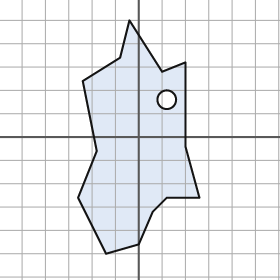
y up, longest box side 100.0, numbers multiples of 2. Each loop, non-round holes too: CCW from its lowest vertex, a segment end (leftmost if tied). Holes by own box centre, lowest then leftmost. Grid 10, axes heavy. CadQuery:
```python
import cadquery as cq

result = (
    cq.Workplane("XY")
    .moveTo(-14.0, -50.0)
    .lineTo(0.0, -46.0)
    .lineTo(6.0, -32.0)
    .lineTo(12.0, -26.0)
    .lineTo(26.0, -26.0)
    .lineTo(20.0, -4.0)
    .lineTo(20.0, 32.0)
    .lineTo(10.0, 28.0)
    .lineTo(-4.0, 50.0)
    .lineTo(-8.0, 34.0)
    .lineTo(-24.0, 24.0)
    .lineTo(-18.0, -6.0)
    .lineTo(-26.0, -26.0)
    .close()
    .moveTo(12.0, 16.0)
    .circle(4.0)
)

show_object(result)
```